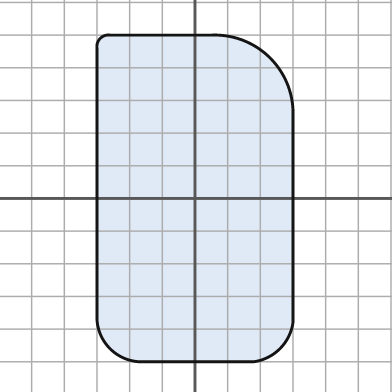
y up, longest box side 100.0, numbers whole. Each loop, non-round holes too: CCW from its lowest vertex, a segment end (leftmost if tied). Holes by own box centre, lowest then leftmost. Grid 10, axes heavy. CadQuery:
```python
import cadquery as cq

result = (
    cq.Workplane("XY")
    .moveTo(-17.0, -50.0)
    .lineTo(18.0, -50.0)
    .threePointArc((26.0, -46.0), (30.0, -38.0))
    .lineTo(30.0, 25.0)
    .threePointArc((23.0, 43.0), (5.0, 50.0))
    .lineTo(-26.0, 50.0)
    .threePointArc((-29.0, 49.0), (-30.0, 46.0))
    .lineTo(-30.0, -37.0)
    .threePointArc((-26.0, -46.0), (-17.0, -50.0))
    .close()
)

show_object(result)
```